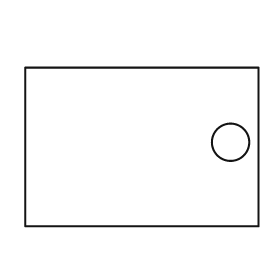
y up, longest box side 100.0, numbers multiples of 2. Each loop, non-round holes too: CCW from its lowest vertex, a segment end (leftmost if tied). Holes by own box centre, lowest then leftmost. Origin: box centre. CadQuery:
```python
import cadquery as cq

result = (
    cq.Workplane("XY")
    .moveTo(-50.0, -34.0)
    .lineTo(50.0, -34.0)
    .lineTo(50.0, 34.0)
    .lineTo(-50.0, 34.0)
    .close()
    .moveTo(38.0, 2.0)
    .circle(8.0)
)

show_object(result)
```